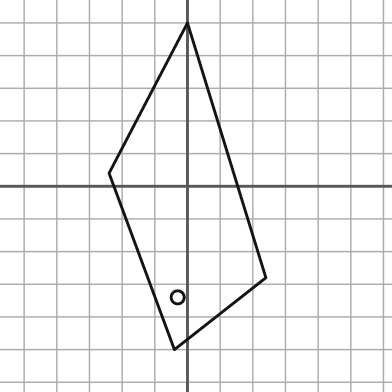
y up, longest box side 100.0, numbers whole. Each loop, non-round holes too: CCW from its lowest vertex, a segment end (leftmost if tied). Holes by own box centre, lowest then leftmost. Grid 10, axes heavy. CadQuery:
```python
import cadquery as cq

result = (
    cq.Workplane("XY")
    .moveTo(-4.0, -50.0)
    .lineTo(24.0, -28.0)
    .lineTo(0.0, 50.0)
    .lineTo(-24.0, 4.0)
    .close()
    .moveTo(-3.0, -34.0)
    .circle(2.0)
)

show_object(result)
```